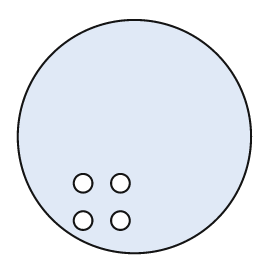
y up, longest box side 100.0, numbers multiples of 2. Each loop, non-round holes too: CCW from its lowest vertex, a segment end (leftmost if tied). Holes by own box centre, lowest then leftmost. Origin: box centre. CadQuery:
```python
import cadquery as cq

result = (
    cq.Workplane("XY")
    .moveTo(0.0, 0.0)
    .circle(50.0)
    .moveTo(-22.0, -36.0)
    .circle(4.0)
    .moveTo(-6.0, -36.0)
    .circle(4.0)
    .moveTo(-22.0, -20.0)
    .circle(4.0)
    .moveTo(-6.0, -20.0)
    .circle(4.0)
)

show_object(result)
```